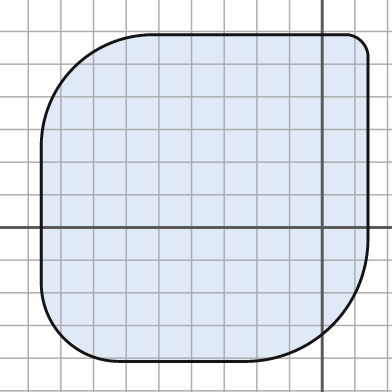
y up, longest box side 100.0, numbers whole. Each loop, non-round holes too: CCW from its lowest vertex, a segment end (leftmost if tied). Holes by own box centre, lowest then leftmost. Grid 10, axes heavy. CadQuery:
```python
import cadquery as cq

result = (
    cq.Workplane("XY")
    .moveTo(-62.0, -41.0)
    .lineTo(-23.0, -41.0)
    .threePointArc((3.0, -30.0), (14.0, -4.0))
    .lineTo(14.0, 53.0)
    .threePointArc((12.0, 57.0), (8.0, 59.0))
    .lineTo(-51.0, 59.0)
    .threePointArc((-76.0, 49.0), (-86.0, 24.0))
    .lineTo(-86.0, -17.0)
    .threePointArc((-79.0, -34.0), (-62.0, -41.0))
    .close()
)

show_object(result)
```